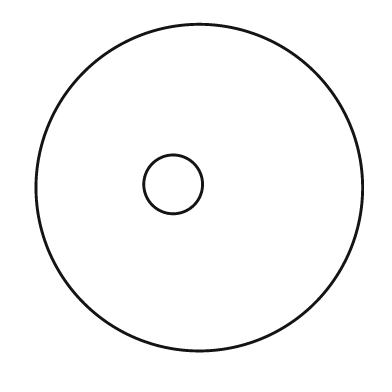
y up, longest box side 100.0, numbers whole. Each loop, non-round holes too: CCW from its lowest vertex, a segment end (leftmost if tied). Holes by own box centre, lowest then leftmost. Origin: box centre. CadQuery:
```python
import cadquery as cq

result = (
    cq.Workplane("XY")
    .moveTo(0.0, 0.0)
    .circle(50.0)
    .moveTo(-8.0, 1.0)
    .circle(9.0)
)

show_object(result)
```